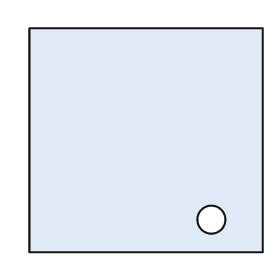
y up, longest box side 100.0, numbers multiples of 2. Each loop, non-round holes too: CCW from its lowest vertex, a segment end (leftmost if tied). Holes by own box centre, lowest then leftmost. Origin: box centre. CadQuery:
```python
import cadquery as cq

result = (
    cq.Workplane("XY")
    .moveTo(-50.0, -48.0)
    .lineTo(50.0, -48.0)
    .lineTo(50.0, 48.0)
    .lineTo(-50.0, 48.0)
    .close()
    .moveTo(28.0, -34.0)
    .circle(6.0)
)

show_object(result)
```